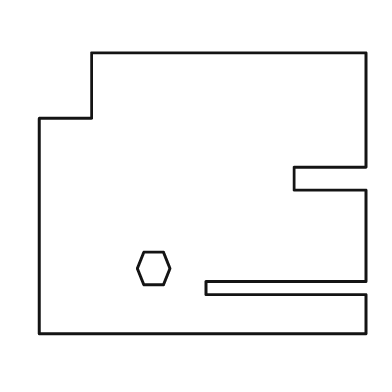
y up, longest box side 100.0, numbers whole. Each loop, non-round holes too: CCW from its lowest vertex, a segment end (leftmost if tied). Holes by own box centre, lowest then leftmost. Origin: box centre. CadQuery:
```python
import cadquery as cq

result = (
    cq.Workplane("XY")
    .moveTo(-50.0, -43.0)
    .lineTo(50.0, -43.0)
    .lineTo(50.0, -31.0)
    .lineTo(1.0, -31.0)
    .lineTo(1.0, -27.0)
    .lineTo(50.0, -27.0)
    .lineTo(50.0, 1.0)
    .lineTo(28.0, 1.0)
    .lineTo(28.0, 8.0)
    .lineTo(50.0, 8.0)
    .lineTo(50.0, 43.0)
    .lineTo(-34.0, 43.0)
    .lineTo(-34.0, 23.0)
    .lineTo(-50.0, 23.0)
    .close()
    .moveTo(-18.0, -28.0)
    .lineTo(-12.0, -28.0)
    .lineTo(-10.0, -23.0)
    .lineTo(-12.0, -18.0)
    .lineTo(-18.0, -18.0)
    .lineTo(-20.0, -23.0)
    .close()
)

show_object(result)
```